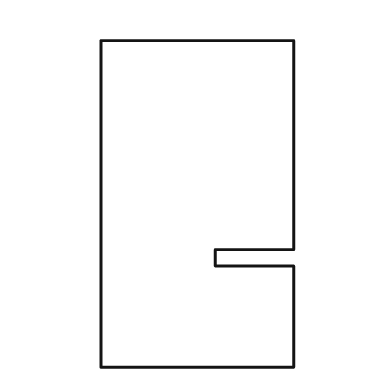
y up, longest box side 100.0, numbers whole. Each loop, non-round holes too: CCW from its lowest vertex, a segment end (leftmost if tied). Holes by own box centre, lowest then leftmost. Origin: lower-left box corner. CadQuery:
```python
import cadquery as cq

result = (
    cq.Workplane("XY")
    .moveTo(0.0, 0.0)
    .lineTo(59.0, 0.0)
    .lineTo(59.0, 31.0)
    .lineTo(35.0, 31.0)
    .lineTo(35.0, 36.0)
    .lineTo(59.0, 36.0)
    .lineTo(59.0, 100.0)
    .lineTo(0.0, 100.0)
    .close()
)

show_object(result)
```